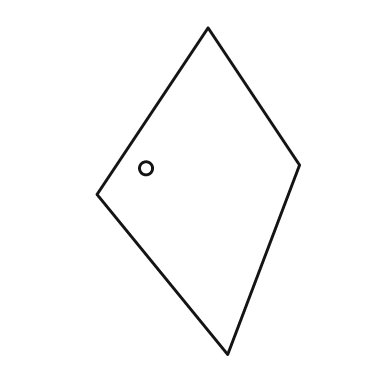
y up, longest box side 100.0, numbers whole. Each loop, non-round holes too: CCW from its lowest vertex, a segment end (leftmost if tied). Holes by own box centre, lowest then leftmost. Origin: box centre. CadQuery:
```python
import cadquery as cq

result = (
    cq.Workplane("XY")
    .moveTo(9.0, -50.0)
    .lineTo(31.0, 8.0)
    .lineTo(3.0, 50.0)
    .lineTo(-31.0, -1.0)
    .close()
    .moveTo(-16.0, 7.0)
    .circle(2.0)
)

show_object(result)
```